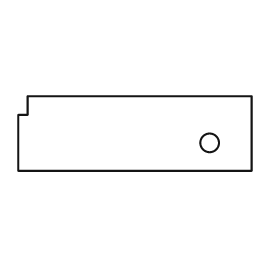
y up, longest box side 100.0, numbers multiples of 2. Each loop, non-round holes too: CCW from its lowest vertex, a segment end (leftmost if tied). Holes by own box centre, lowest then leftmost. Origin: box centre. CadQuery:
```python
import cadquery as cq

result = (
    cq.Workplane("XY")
    .moveTo(-50.0, -16.0)
    .lineTo(50.0, -16.0)
    .lineTo(50.0, 16.0)
    .lineTo(-46.0, 16.0)
    .lineTo(-46.0, 8.0)
    .lineTo(-50.0, 8.0)
    .close()
    .moveTo(32.0, -4.0)
    .circle(4.0)
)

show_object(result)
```